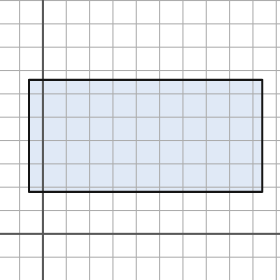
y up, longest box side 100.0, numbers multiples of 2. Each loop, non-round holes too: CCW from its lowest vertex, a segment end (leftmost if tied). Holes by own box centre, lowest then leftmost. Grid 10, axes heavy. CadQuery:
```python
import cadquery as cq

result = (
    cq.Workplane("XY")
    .moveTo(-6.0, 18.0)
    .lineTo(94.0, 18.0)
    .lineTo(94.0, 66.0)
    .lineTo(-6.0, 66.0)
    .close()
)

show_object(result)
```